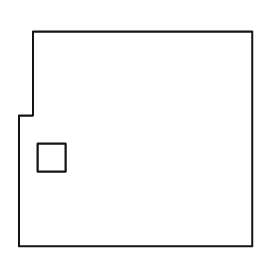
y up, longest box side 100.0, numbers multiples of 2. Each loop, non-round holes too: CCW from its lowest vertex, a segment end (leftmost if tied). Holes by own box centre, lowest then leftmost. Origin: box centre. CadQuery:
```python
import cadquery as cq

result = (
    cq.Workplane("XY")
    .moveTo(-50.0, -46.0)
    .lineTo(50.0, -46.0)
    .lineTo(50.0, 46.0)
    .lineTo(-44.0, 46.0)
    .lineTo(-44.0, 10.0)
    .lineTo(-50.0, 10.0)
    .close()
    .moveTo(-42.0, -14.0)
    .lineTo(-30.0, -14.0)
    .lineTo(-30.0, -2.0)
    .lineTo(-42.0, -2.0)
    .close()
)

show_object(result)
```